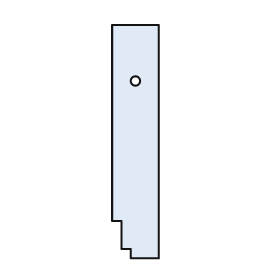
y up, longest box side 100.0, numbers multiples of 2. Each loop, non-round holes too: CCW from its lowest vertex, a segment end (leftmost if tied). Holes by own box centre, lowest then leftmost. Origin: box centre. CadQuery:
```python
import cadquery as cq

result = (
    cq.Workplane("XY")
    .moveTo(-2.0, -50.0)
    .lineTo(10.0, -50.0)
    .lineTo(10.0, 50.0)
    .lineTo(-10.0, 50.0)
    .lineTo(-10.0, -34.0)
    .lineTo(-6.0, -34.0)
    .lineTo(-6.0, -46.0)
    .lineTo(-2.0, -46.0)
    .close()
    .moveTo(0.0, 26.0)
    .circle(2.0)
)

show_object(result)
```